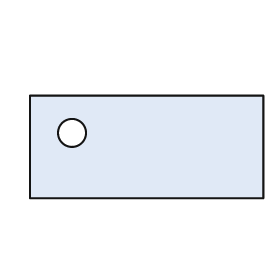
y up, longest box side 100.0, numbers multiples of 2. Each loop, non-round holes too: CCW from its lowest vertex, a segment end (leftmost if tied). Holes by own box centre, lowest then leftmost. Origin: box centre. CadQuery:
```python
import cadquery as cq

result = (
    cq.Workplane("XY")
    .moveTo(-50.0, -22.0)
    .lineTo(50.0, -22.0)
    .lineTo(50.0, 22.0)
    .lineTo(-50.0, 22.0)
    .close()
    .moveTo(-32.0, 6.0)
    .circle(6.0)
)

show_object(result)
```